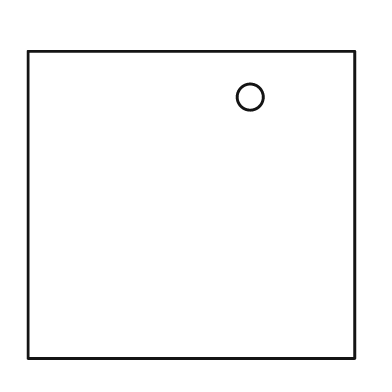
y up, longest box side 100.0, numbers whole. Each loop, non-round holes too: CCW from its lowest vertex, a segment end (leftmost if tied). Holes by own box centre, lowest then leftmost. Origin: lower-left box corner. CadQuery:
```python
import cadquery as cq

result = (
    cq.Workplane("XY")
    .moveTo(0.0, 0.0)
    .lineTo(100.0, 0.0)
    .lineTo(100.0, 94.0)
    .lineTo(0.0, 94.0)
    .close()
    .moveTo(68.0, 80.0)
    .circle(4.0)
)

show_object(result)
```